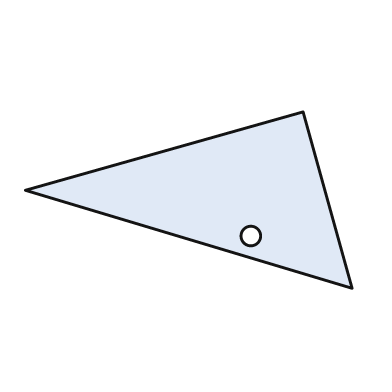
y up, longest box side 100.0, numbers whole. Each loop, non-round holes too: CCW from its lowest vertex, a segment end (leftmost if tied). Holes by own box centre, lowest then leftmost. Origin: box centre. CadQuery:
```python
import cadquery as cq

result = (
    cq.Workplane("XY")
    .moveTo(50.0, -27.0)
    .lineTo(35.0, 27.0)
    .lineTo(-50.0, 3.0)
    .close()
    .moveTo(19.0, -11.0)
    .circle(3.0)
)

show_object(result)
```